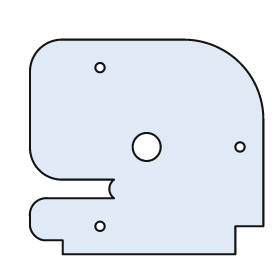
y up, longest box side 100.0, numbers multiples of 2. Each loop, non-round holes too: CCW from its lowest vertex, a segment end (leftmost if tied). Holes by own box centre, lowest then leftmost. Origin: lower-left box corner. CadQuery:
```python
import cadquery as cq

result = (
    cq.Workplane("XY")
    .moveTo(14.0, 0.0)
    .lineTo(88.0, 0.0)
    .lineTo(88.0, 12.0)
    .lineTo(100.0, 12.0)
    .lineTo(100.0, 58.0)
    .threePointArc((90.0, 82.0), (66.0, 92.0))
    .lineTo(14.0, 92.0)
    .threePointArc((4.0, 88.0), (0.0, 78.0))
    .lineTo(0.0, 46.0)
    .threePointArc((4.0, 36.0), (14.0, 32.0))
    .lineTo(36.0, 32.0)
    .threePointArc((34.0, 28.0), (36.0, 24.0))
    .lineTo(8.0, 24.0)
    .threePointArc((2.0, 22.0), (0.0, 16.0))
    .lineTo(0.0, 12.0)
    .threePointArc((2.0, 8.0), (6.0, 6.0))
    .lineTo(14.0, 6.0)
    .close()
    .moveTo(30.0, 12.0)
    .circle(2.0)
    .moveTo(50.0, 46.0)
    .circle(6.0)
    .moveTo(90.0, 46.0)
    .circle(2.0)
    .moveTo(30.0, 80.0)
    .circle(2.0)
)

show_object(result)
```